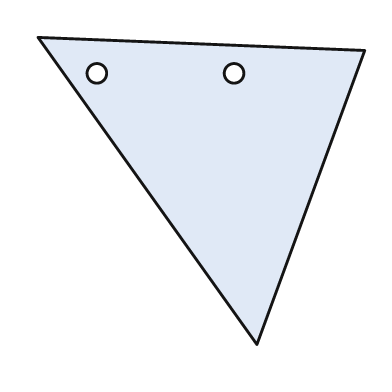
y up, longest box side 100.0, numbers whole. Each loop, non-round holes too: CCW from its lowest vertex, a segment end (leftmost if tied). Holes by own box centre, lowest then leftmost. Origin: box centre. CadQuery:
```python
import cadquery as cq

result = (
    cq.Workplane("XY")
    .moveTo(17.0, -47.0)
    .lineTo(50.0, 43.0)
    .lineTo(-50.0, 47.0)
    .close()
    .moveTo(-32.0, 36.0)
    .circle(3.0)
    .moveTo(10.0, 36.0)
    .circle(3.0)
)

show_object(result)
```